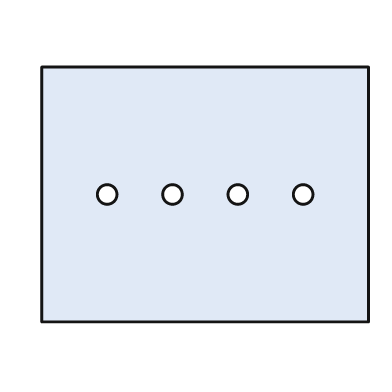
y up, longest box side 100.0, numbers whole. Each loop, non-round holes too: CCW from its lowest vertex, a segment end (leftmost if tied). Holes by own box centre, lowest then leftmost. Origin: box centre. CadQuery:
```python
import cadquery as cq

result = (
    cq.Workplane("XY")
    .moveTo(-50.0, -39.0)
    .lineTo(50.0, -39.0)
    .lineTo(50.0, 39.0)
    .lineTo(-50.0, 39.0)
    .close()
    .moveTo(-30.0, 0.0)
    .circle(3.0)
    .moveTo(-10.0, 0.0)
    .circle(3.0)
    .moveTo(10.0, 0.0)
    .circle(3.0)
    .moveTo(30.0, 0.0)
    .circle(3.0)
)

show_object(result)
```